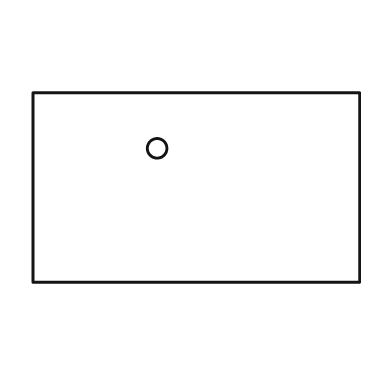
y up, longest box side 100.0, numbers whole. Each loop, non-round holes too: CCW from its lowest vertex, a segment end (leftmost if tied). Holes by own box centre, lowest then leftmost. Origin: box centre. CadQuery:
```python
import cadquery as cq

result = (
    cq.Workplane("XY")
    .moveTo(-50.0, -29.0)
    .lineTo(50.0, -29.0)
    .lineTo(50.0, 29.0)
    .lineTo(-50.0, 29.0)
    .close()
    .moveTo(-12.0, 12.0)
    .circle(3.0)
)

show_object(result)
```